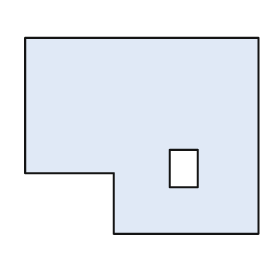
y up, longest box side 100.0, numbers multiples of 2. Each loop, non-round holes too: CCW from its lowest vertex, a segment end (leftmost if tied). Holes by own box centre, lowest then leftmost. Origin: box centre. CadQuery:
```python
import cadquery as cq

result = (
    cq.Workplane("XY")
    .moveTo(-12.0, -42.0)
    .lineTo(50.0, -42.0)
    .lineTo(50.0, 42.0)
    .lineTo(-50.0, 42.0)
    .lineTo(-50.0, -16.0)
    .lineTo(-12.0, -16.0)
    .close()
    .moveTo(12.0, -22.0)
    .lineTo(24.0, -22.0)
    .lineTo(24.0, -6.0)
    .lineTo(12.0, -6.0)
    .close()
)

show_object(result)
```